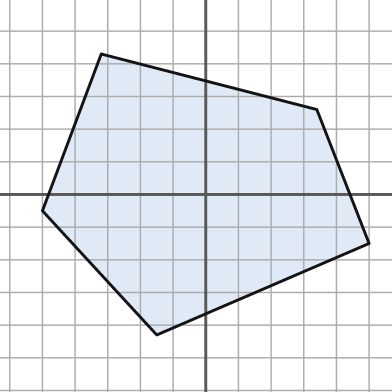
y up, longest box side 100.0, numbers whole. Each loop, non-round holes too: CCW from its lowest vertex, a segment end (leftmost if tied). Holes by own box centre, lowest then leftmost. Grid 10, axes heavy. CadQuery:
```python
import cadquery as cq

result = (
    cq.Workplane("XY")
    .moveTo(-15.0, -43.0)
    .lineTo(50.0, -15.0)
    .lineTo(34.0, 26.0)
    .lineTo(-32.0, 43.0)
    .lineTo(-50.0, -5.0)
    .close()
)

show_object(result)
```